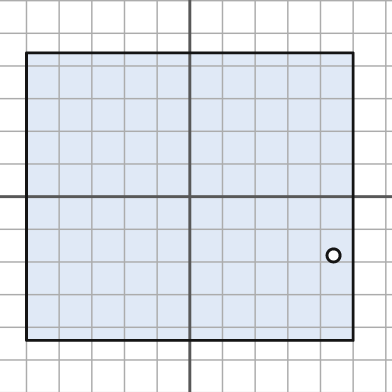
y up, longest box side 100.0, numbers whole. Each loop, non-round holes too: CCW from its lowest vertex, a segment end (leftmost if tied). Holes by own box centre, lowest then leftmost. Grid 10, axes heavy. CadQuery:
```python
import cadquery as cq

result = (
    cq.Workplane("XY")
    .moveTo(-50.0, -44.0)
    .lineTo(50.0, -44.0)
    .lineTo(50.0, 44.0)
    .lineTo(-50.0, 44.0)
    .close()
    .moveTo(44.0, -18.0)
    .circle(2.0)
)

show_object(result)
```